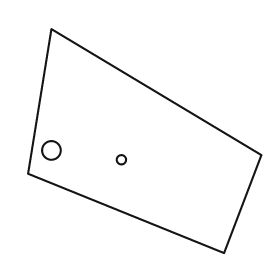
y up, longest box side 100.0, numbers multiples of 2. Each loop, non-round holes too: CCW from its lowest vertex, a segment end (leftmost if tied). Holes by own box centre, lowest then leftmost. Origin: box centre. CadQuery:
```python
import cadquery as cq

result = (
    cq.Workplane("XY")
    .moveTo(34.0, -48.0)
    .lineTo(50.0, -6.0)
    .lineTo(-40.0, 48.0)
    .lineTo(-50.0, -14.0)
    .close()
    .moveTo(-10.0, -8.0)
    .circle(2.0)
    .moveTo(-40.0, -4.0)
    .circle(4.0)
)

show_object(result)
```